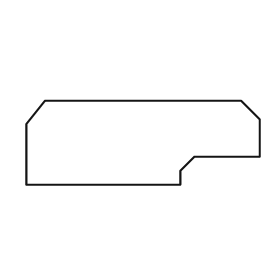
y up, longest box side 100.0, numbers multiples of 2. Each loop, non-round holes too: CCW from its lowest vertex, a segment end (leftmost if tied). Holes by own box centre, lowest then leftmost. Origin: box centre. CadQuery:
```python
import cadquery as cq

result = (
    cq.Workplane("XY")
    .moveTo(-50.0, -18.0)
    .lineTo(16.0, -18.0)
    .lineTo(16.0, -12.0)
    .lineTo(22.0, -6.0)
    .lineTo(50.0, -6.0)
    .lineTo(50.0, 10.0)
    .lineTo(42.0, 18.0)
    .lineTo(-42.0, 18.0)
    .lineTo(-50.0, 8.0)
    .close()
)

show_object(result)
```